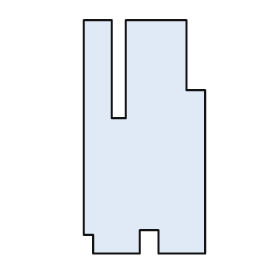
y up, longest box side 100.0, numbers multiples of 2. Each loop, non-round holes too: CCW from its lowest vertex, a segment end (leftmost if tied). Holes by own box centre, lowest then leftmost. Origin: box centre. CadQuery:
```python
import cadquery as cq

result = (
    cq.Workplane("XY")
    .moveTo(-22.0, -50.0)
    .lineTo(-2.0, -50.0)
    .lineTo(-2.0, -40.0)
    .lineTo(6.0, -40.0)
    .lineTo(6.0, -50.0)
    .lineTo(26.0, -50.0)
    .lineTo(26.0, 20.0)
    .lineTo(18.0, 20.0)
    .lineTo(18.0, 50.0)
    .lineTo(-8.0, 50.0)
    .lineTo(-8.0, 8.0)
    .lineTo(-14.0, 8.0)
    .lineTo(-14.0, 50.0)
    .lineTo(-26.0, 50.0)
    .lineTo(-26.0, -42.0)
    .lineTo(-22.0, -42.0)
    .close()
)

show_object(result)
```